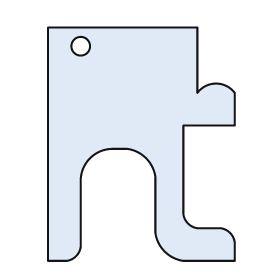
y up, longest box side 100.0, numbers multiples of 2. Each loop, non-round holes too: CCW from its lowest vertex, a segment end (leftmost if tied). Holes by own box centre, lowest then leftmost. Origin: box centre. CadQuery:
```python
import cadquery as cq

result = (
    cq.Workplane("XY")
    .moveTo(-40.0, -50.0)
    .lineTo(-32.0, -50.0)
    .threePointArc((-28.0, -48.0), (-26.0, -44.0))
    .lineTo(-26.0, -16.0)
    .threePointArc((-22.0, -6.0), (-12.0, -2.0))
    .lineTo(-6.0, -2.0)
    .threePointArc((2.0, -6.0), (6.0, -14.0))
    .lineTo(6.0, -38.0)
    .threePointArc((10.0, -46.0), (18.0, -50.0))
    .lineTo(40.0, -50.0)
    .lineTo(40.0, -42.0)
    .threePointArc((38.0, -38.0), (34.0, -36.0))
    .lineTo(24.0, -36.0)
    .threePointArc((20.0, -34.0), (18.0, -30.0))
    .lineTo(18.0, 8.0)
    .lineTo(40.0, 8.0)
    .lineTo(40.0, 22.0)
    .threePointArc((32.0, 26.0), (24.0, 22.0))
    .lineTo(24.0, 50.0)
    .lineTo(-40.0, 50.0)
    .close()
    .moveTo(-26.0, 42.0)
    .circle(4.0)
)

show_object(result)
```